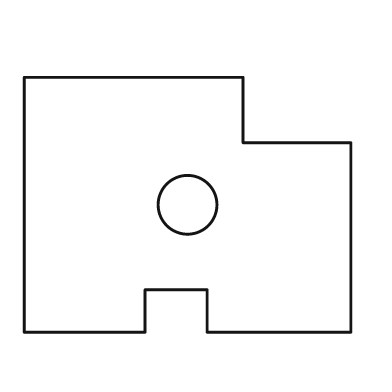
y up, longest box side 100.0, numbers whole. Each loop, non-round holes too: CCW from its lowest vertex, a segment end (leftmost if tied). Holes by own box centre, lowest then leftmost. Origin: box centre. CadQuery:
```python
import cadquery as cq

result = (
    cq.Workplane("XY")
    .moveTo(-50.0, -39.0)
    .lineTo(-13.0, -39.0)
    .lineTo(-13.0, -26.0)
    .lineTo(6.0, -26.0)
    .lineTo(6.0, -39.0)
    .lineTo(50.0, -39.0)
    .lineTo(50.0, 19.0)
    .lineTo(17.0, 19.0)
    .lineTo(17.0, 39.0)
    .lineTo(-50.0, 39.0)
    .close()
    .moveTo(0.0, 0.0)
    .circle(9.0)
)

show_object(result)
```